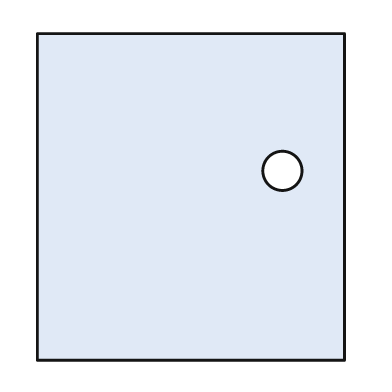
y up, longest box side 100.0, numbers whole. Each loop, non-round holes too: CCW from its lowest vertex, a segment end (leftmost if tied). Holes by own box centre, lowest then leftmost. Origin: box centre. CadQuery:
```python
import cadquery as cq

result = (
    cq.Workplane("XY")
    .moveTo(-47.0, -50.0)
    .lineTo(47.0, -50.0)
    .lineTo(47.0, 50.0)
    .lineTo(-47.0, 50.0)
    .close()
    .moveTo(28.0, 8.0)
    .circle(6.0)
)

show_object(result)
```